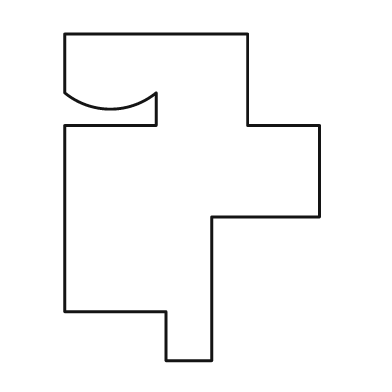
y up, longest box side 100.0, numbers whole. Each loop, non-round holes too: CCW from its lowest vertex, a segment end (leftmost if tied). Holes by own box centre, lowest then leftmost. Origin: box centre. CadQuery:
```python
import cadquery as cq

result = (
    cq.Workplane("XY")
    .moveTo(-8.0, -50.0)
    .lineTo(6.0, -50.0)
    .lineTo(6.0, -6.0)
    .lineTo(39.0, -6.0)
    .lineTo(39.0, 22.0)
    .lineTo(17.0, 22.0)
    .lineTo(17.0, 50.0)
    .lineTo(-39.0, 50.0)
    .lineTo(-39.0, 32.0)
    .threePointArc((-25.0, 27.0), (-11.0, 32.0))
    .lineTo(-11.0, 22.0)
    .lineTo(-39.0, 22.0)
    .lineTo(-39.0, -35.0)
    .lineTo(-8.0, -35.0)
    .close()
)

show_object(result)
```